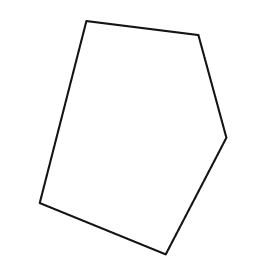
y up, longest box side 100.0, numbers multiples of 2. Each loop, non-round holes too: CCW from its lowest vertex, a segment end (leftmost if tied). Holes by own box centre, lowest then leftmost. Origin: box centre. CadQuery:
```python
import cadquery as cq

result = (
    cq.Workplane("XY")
    .moveTo(14.0, -50.0)
    .lineTo(40.0, 0.0)
    .lineTo(28.0, 44.0)
    .lineTo(-20.0, 50.0)
    .lineTo(-40.0, -28.0)
    .close()
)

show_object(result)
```